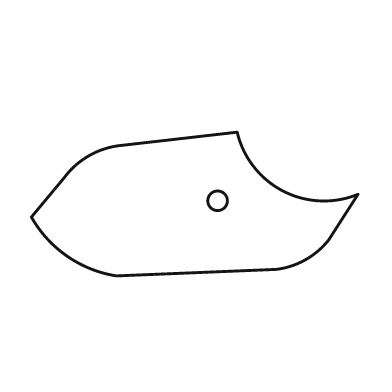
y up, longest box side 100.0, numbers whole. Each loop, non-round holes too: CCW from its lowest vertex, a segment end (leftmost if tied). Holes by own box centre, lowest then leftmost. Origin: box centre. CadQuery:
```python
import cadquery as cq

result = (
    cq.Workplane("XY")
    .moveTo(-24.0, -22.0)
    .lineTo(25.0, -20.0)
    .threePointArc((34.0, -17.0), (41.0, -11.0))
    .lineTo(50.0, 3.0)
    .threePointArc((27.0, 4.0), (13.0, 22.0))
    .lineTo(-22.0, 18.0)
    .threePointArc((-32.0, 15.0), (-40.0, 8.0))
    .lineTo(-50.0, -4.0)
    .threePointArc((-39.0, -16.0), (-24.0, -22.0))
    .close()
    .moveTo(7.0, 1.0)
    .circle(3.0)
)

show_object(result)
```